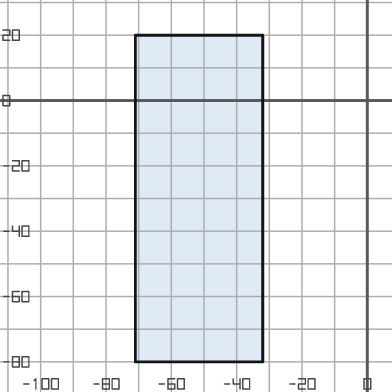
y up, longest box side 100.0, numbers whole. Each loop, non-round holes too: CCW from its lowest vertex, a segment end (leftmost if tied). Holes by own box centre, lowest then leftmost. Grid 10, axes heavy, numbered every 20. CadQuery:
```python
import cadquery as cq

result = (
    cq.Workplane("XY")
    .moveTo(-71.0, -80.0)
    .lineTo(-32.0, -80.0)
    .lineTo(-32.0, 20.0)
    .lineTo(-71.0, 20.0)
    .close()
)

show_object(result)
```